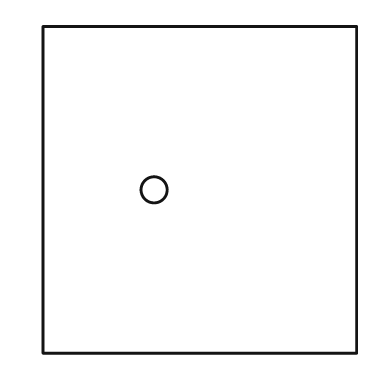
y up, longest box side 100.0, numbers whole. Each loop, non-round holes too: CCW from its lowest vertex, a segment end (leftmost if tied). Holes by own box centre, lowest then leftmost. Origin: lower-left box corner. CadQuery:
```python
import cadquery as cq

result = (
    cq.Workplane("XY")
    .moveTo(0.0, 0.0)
    .lineTo(96.0, 0.0)
    .lineTo(96.0, 100.0)
    .lineTo(0.0, 100.0)
    .close()
    .moveTo(34.0, 50.0)
    .circle(4.0)
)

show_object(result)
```